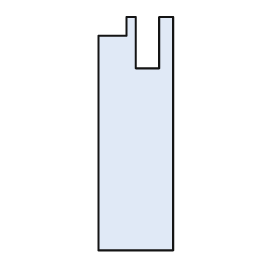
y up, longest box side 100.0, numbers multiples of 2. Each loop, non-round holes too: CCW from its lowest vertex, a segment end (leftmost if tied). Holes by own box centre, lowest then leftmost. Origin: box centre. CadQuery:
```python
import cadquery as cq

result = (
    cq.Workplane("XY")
    .moveTo(-16.0, -50.0)
    .lineTo(16.0, -50.0)
    .lineTo(16.0, 50.0)
    .lineTo(10.0, 50.0)
    .lineTo(10.0, 28.0)
    .lineTo(0.0, 28.0)
    .lineTo(0.0, 50.0)
    .lineTo(-4.0, 50.0)
    .lineTo(-4.0, 42.0)
    .lineTo(-16.0, 42.0)
    .close()
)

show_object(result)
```